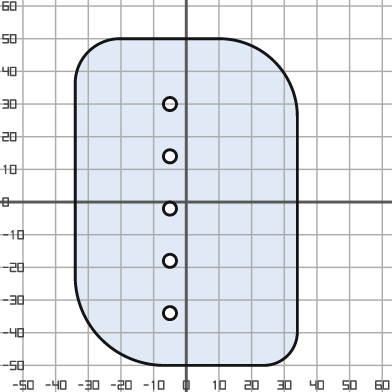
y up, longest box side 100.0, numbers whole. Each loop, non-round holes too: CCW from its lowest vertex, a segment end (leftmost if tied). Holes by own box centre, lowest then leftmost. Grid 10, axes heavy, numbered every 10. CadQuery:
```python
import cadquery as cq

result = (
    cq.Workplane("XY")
    .moveTo(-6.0, -50.0)
    .lineTo(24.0, -50.0)
    .threePointArc((31.0, -47.0), (34.0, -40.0))
    .lineTo(34.0, 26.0)
    .threePointArc((27.0, 43.0), (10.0, 50.0))
    .lineTo(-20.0, 50.0)
    .threePointArc((-30.0, 46.0), (-34.0, 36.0))
    .lineTo(-34.0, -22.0)
    .threePointArc((-26.0, -42.0), (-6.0, -50.0))
    .close()
    .moveTo(-5.0, -34.0)
    .circle(2.0)
    .moveTo(-5.0, -18.0)
    .circle(2.0)
    .moveTo(-5.0, -2.0)
    .circle(2.0)
    .moveTo(-5.0, 14.0)
    .circle(2.0)
    .moveTo(-5.0, 30.0)
    .circle(2.0)
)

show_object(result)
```